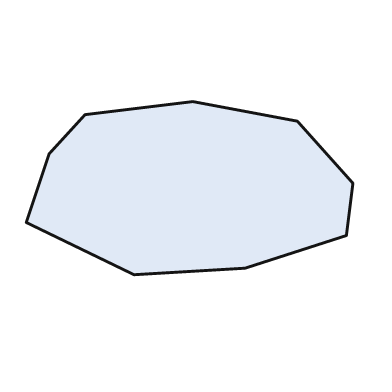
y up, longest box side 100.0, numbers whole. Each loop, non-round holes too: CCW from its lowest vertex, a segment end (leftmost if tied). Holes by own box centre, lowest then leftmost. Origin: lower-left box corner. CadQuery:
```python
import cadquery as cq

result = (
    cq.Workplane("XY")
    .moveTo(33.0, 0.0)
    .lineTo(67.0, 2.0)
    .lineTo(98.0, 12.0)
    .lineTo(100.0, 28.0)
    .lineTo(83.0, 47.0)
    .lineTo(51.0, 53.0)
    .lineTo(18.0, 49.0)
    .lineTo(7.0, 37.0)
    .lineTo(0.0, 16.0)
    .close()
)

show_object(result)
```